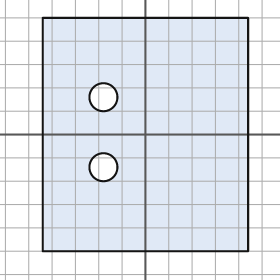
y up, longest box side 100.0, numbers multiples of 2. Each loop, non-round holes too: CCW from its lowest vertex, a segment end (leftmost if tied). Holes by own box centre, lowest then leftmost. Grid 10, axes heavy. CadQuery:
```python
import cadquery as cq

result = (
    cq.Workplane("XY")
    .moveTo(-44.0, -50.0)
    .lineTo(44.0, -50.0)
    .lineTo(44.0, 50.0)
    .lineTo(-44.0, 50.0)
    .close()
    .moveTo(-18.0, -14.0)
    .circle(6.0)
    .moveTo(-18.0, 16.0)
    .circle(6.0)
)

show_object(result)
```